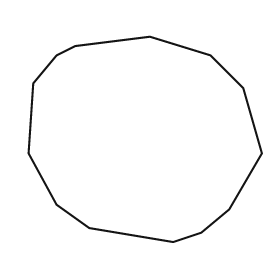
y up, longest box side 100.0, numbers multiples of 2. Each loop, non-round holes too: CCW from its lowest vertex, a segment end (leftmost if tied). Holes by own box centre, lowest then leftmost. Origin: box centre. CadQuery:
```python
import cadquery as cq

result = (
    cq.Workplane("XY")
    .moveTo(12.0, -44.0)
    .lineTo(24.0, -40.0)
    .lineTo(36.0, -30.0)
    .lineTo(50.0, -6.0)
    .lineTo(42.0, 22.0)
    .lineTo(28.0, 36.0)
    .lineTo(2.0, 44.0)
    .lineTo(-30.0, 40.0)
    .lineTo(-38.0, 36.0)
    .lineTo(-48.0, 24.0)
    .lineTo(-50.0, -6.0)
    .lineTo(-38.0, -28.0)
    .lineTo(-24.0, -38.0)
    .close()
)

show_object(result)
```